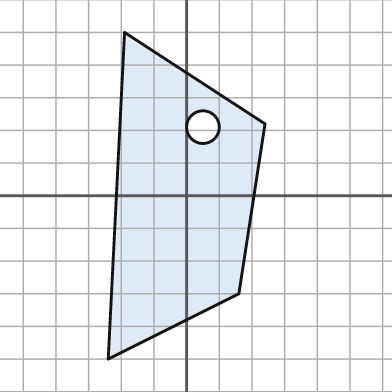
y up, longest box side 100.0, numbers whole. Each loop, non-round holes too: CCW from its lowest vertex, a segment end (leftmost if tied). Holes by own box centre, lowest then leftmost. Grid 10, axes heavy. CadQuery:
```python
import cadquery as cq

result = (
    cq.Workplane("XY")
    .moveTo(-24.0, -50.0)
    .lineTo(16.0, -30.0)
    .lineTo(24.0, 22.0)
    .lineTo(-19.0, 50.0)
    .close()
    .moveTo(5.0, 21.0)
    .circle(5.0)
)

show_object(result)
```